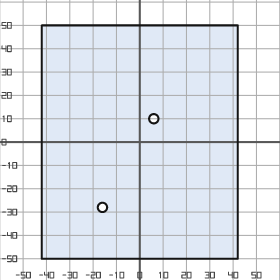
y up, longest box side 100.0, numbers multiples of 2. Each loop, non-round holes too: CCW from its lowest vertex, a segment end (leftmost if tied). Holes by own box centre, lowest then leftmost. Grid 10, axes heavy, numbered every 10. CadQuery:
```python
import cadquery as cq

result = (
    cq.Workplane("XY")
    .moveTo(-42.0, -50.0)
    .lineTo(42.0, -50.0)
    .lineTo(42.0, 50.0)
    .lineTo(-42.0, 50.0)
    .close()
    .moveTo(-16.0, -28.0)
    .circle(2.0)
    .moveTo(6.0, 10.0)
    .circle(2.0)
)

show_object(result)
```